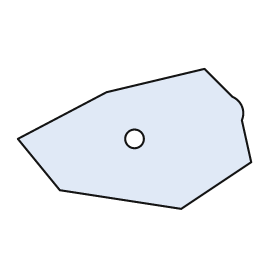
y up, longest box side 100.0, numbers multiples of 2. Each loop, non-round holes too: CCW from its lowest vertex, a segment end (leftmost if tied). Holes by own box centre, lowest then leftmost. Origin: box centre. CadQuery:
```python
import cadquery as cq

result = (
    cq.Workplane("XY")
    .moveTo(20.0, -30.0)
    .lineTo(50.0, -10.0)
    .lineTo(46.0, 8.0)
    .threePointArc((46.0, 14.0), (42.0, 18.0))
    .lineTo(30.0, 30.0)
    .lineTo(-12.0, 20.0)
    .lineTo(-50.0, 0.0)
    .lineTo(-32.0, -22.0)
    .close()
    .moveTo(0.0, 0.0)
    .circle(4.0)
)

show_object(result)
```